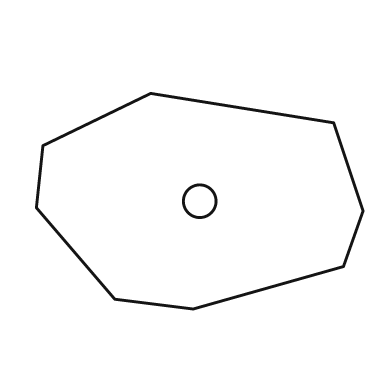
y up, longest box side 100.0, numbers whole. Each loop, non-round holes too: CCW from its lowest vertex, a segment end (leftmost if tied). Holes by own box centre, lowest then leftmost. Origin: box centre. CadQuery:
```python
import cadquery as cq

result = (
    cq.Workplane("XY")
    .moveTo(-2.0, -33.0)
    .lineTo(44.0, -20.0)
    .lineTo(50.0, -3.0)
    .lineTo(41.0, 24.0)
    .lineTo(-15.0, 33.0)
    .lineTo(-48.0, 17.0)
    .lineTo(-50.0, -2.0)
    .lineTo(-26.0, -30.0)
    .close()
    .moveTo(0.0, 0.0)
    .circle(5.0)
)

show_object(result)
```